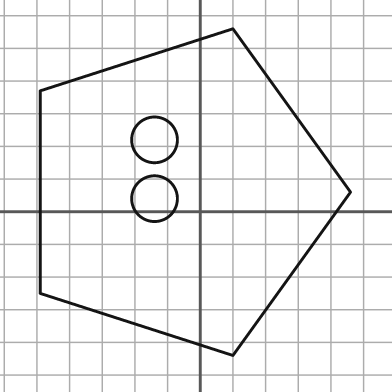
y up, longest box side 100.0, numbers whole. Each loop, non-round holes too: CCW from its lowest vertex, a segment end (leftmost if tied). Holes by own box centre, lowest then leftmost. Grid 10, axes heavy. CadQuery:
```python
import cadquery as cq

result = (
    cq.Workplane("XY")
    .moveTo(10.0, -44.0)
    .lineTo(46.0, 6.0)
    .lineTo(10.0, 56.0)
    .lineTo(-49.0, 37.0)
    .lineTo(-49.0, -25.0)
    .close()
    .moveTo(-14.0, 4.0)
    .circle(7.0)
    .moveTo(-14.0, 22.0)
    .circle(7.0)
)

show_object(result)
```